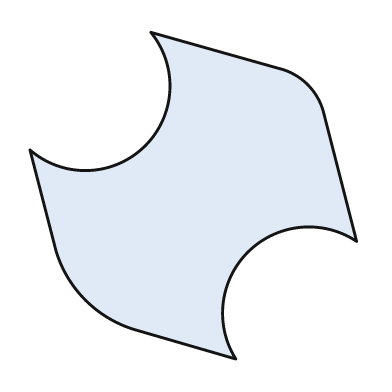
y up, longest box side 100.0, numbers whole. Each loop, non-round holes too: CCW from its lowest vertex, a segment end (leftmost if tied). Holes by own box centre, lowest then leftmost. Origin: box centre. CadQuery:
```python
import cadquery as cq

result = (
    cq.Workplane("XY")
    .moveTo(13.0, -50.0)
    .threePointArc((17.0, -17.0), (50.0, -14.0))
    .lineTo(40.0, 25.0)
    .threePointArc((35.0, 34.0), (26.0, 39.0))
    .lineTo(-13.0, 50.0)
    .threePointArc((-15.0, 15.0), (-50.0, 14.0))
    .lineTo(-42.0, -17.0)
    .threePointArc((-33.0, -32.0), (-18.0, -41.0))
    .close()
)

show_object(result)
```